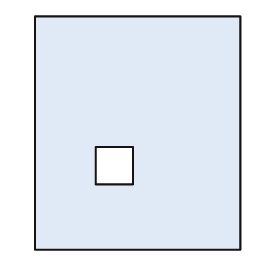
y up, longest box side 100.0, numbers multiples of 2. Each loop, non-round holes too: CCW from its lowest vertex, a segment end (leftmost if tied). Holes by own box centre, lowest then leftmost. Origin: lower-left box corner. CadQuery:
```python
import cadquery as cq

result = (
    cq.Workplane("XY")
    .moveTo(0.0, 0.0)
    .lineTo(88.0, 0.0)
    .lineTo(88.0, 100.0)
    .lineTo(0.0, 100.0)
    .close()
    .moveTo(26.0, 28.0)
    .lineTo(42.0, 28.0)
    .lineTo(42.0, 44.0)
    .lineTo(26.0, 44.0)
    .close()
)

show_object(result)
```